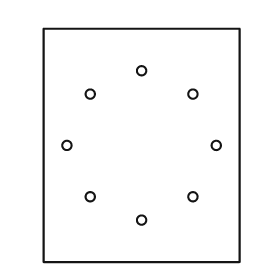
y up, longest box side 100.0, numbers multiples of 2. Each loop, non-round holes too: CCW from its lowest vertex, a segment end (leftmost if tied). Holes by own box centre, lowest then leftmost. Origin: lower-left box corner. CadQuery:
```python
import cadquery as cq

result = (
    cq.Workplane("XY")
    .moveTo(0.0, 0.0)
    .lineTo(84.0, 0.0)
    .lineTo(84.0, 100.0)
    .lineTo(0.0, 100.0)
    .close()
    .moveTo(42.0, 18.0)
    .circle(2.0)
    .moveTo(20.0, 28.0)
    .circle(2.0)
    .moveTo(64.0, 28.0)
    .circle(2.0)
    .moveTo(10.0, 50.0)
    .circle(2.0)
    .moveTo(74.0, 50.0)
    .circle(2.0)
    .moveTo(20.0, 72.0)
    .circle(2.0)
    .moveTo(64.0, 72.0)
    .circle(2.0)
    .moveTo(42.0, 82.0)
    .circle(2.0)
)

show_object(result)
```